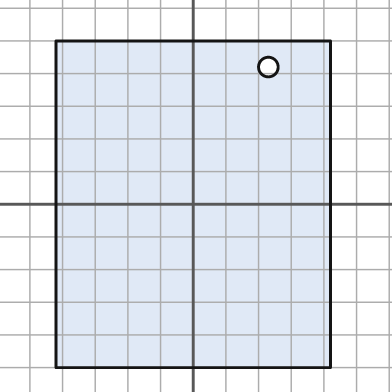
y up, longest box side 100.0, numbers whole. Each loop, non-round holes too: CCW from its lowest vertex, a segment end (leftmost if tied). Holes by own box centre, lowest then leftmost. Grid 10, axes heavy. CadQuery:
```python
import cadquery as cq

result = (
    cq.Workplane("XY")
    .moveTo(-42.0, -50.0)
    .lineTo(42.0, -50.0)
    .lineTo(42.0, 50.0)
    .lineTo(-42.0, 50.0)
    .close()
    .moveTo(23.0, 42.0)
    .circle(3.0)
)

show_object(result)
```